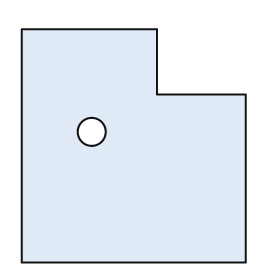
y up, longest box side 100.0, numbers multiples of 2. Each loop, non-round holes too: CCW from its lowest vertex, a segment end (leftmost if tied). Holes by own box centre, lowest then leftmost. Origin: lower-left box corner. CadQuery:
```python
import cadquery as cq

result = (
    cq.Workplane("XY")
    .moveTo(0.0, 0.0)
    .lineTo(96.0, 0.0)
    .lineTo(96.0, 72.0)
    .lineTo(58.0, 72.0)
    .lineTo(58.0, 100.0)
    .lineTo(0.0, 100.0)
    .close()
    .moveTo(30.0, 56.0)
    .circle(6.0)
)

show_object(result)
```